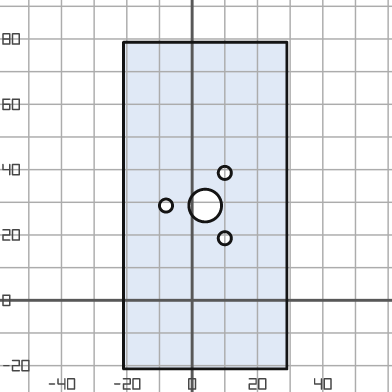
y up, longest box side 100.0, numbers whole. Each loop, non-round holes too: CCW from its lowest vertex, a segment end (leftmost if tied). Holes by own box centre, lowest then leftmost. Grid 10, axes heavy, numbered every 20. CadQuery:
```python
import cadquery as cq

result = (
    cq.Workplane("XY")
    .moveTo(-21.0, -21.0)
    .lineTo(29.0, -21.0)
    .lineTo(29.0, 79.0)
    .lineTo(-21.0, 79.0)
    .close()
    .moveTo(10.0, 19.0)
    .circle(2.0)
    .moveTo(-8.0, 29.0)
    .circle(2.0)
    .moveTo(4.0, 29.0)
    .circle(5.0)
    .moveTo(10.0, 39.0)
    .circle(2.0)
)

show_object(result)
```